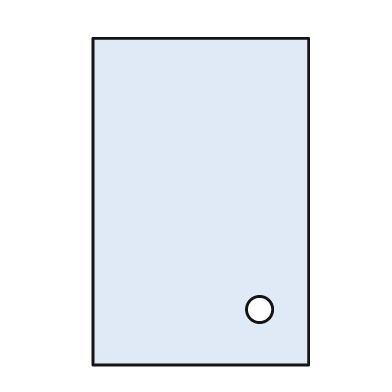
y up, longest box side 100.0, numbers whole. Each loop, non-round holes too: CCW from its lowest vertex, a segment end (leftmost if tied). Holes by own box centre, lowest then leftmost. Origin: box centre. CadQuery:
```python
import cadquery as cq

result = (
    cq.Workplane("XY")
    .moveTo(-33.0, -50.0)
    .lineTo(33.0, -50.0)
    .lineTo(33.0, 50.0)
    .lineTo(-33.0, 50.0)
    .close()
    .moveTo(18.0, -33.0)
    .circle(4.0)
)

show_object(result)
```